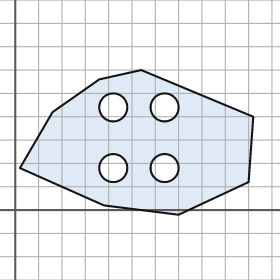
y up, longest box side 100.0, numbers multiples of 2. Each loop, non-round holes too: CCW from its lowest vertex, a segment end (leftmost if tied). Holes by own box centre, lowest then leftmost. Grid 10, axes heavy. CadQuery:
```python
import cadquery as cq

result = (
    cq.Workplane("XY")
    .moveTo(70.0, -2.0)
    .lineTo(100.0, 12.0)
    .lineTo(102.0, 40.0)
    .lineTo(54.0, 60.0)
    .lineTo(36.0, 56.0)
    .lineTo(16.0, 42.0)
    .lineTo(2.0, 18.0)
    .lineTo(38.0, 2.0)
    .close()
    .moveTo(42.0, 18.0)
    .circle(6.0)
    .moveTo(64.0, 18.0)
    .circle(6.0)
    .moveTo(42.0, 44.0)
    .circle(6.0)
    .moveTo(64.0, 44.0)
    .circle(6.0)
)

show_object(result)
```